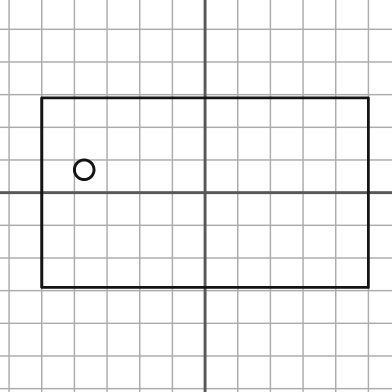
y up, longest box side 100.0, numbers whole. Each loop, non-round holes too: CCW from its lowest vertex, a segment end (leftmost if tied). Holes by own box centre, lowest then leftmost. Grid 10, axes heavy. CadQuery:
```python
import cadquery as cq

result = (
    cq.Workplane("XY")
    .moveTo(-50.0, -29.0)
    .lineTo(50.0, -29.0)
    .lineTo(50.0, 29.0)
    .lineTo(-50.0, 29.0)
    .close()
    .moveTo(-37.0, 7.0)
    .circle(3.0)
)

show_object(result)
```